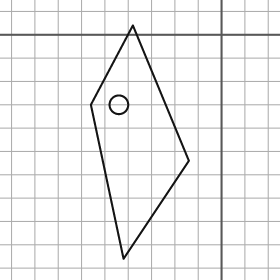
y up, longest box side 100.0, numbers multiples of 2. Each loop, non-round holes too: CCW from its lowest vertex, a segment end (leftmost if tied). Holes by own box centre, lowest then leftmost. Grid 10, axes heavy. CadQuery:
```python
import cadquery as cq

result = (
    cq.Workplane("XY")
    .moveTo(-42.0, -96.0)
    .lineTo(-14.0, -54.0)
    .lineTo(-38.0, 4.0)
    .lineTo(-56.0, -30.0)
    .close()
    .moveTo(-44.0, -30.0)
    .circle(4.0)
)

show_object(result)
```